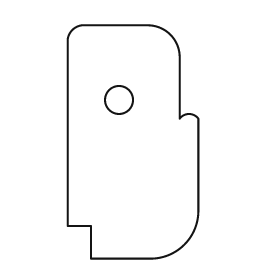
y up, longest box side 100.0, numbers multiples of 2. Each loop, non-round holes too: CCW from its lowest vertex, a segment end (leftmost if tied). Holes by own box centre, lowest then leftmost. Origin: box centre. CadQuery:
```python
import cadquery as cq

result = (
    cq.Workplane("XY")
    .moveTo(-18.0, -50.0)
    .lineTo(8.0, -50.0)
    .threePointArc((22.0, -44.0), (28.0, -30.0))
    .lineTo(28.0, 10.0)
    .threePointArc((24.0, 12.0), (20.0, 10.0))
    .lineTo(20.0, 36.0)
    .threePointArc((16.0, 46.0), (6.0, 50.0))
    .lineTo(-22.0, 50.0)
    .threePointArc((-26.0, 48.0), (-28.0, 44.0))
    .lineTo(-28.0, -36.0)
    .lineTo(-18.0, -36.0)
    .close()
    .moveTo(-6.0, 18.0)
    .circle(6.0)
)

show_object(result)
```